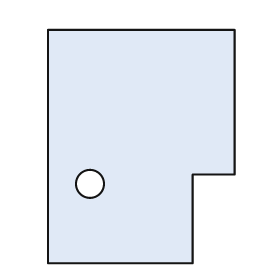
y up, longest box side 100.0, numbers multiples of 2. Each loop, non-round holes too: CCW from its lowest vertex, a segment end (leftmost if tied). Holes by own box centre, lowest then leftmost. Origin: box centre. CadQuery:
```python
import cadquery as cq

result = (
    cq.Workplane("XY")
    .moveTo(-40.0, -50.0)
    .lineTo(22.0, -50.0)
    .lineTo(22.0, -12.0)
    .lineTo(40.0, -12.0)
    .lineTo(40.0, 50.0)
    .lineTo(-40.0, 50.0)
    .close()
    .moveTo(-22.0, -16.0)
    .circle(6.0)
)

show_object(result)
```